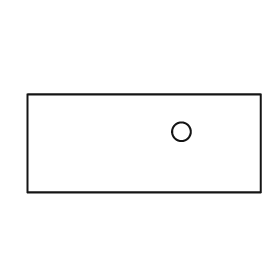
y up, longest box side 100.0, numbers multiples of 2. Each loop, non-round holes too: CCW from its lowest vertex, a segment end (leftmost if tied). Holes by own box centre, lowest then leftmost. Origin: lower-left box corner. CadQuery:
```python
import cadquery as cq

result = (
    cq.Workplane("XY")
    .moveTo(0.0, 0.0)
    .lineTo(100.0, 0.0)
    .lineTo(100.0, 42.0)
    .lineTo(0.0, 42.0)
    .close()
    .moveTo(66.0, 26.0)
    .circle(4.0)
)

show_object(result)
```